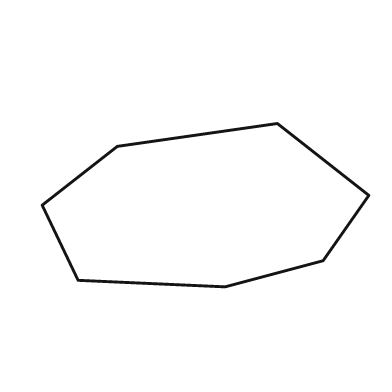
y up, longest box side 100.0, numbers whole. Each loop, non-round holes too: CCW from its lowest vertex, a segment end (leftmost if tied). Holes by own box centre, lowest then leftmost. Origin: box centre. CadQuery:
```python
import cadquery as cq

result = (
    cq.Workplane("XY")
    .moveTo(6.0, -25.0)
    .lineTo(36.0, -17.0)
    .lineTo(50.0, 3.0)
    .lineTo(22.0, 25.0)
    .lineTo(-27.0, 18.0)
    .lineTo(-50.0, 0.0)
    .lineTo(-39.0, -23.0)
    .close()
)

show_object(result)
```